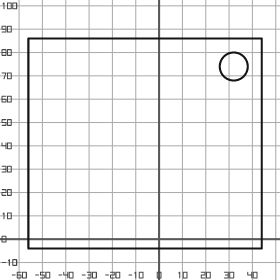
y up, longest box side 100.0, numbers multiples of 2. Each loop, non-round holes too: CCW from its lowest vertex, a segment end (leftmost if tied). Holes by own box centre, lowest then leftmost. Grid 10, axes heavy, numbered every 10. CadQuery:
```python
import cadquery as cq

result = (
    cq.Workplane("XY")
    .moveTo(-56.0, -4.0)
    .lineTo(44.0, -4.0)
    .lineTo(44.0, 86.0)
    .lineTo(-56.0, 86.0)
    .close()
    .moveTo(32.0, 74.0)
    .circle(6.0)
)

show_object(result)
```